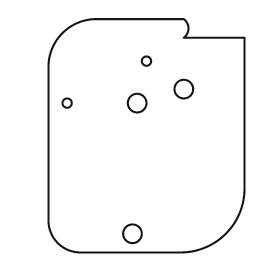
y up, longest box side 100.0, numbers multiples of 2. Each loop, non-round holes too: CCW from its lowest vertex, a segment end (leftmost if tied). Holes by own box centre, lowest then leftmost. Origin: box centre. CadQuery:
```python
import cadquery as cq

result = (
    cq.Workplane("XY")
    .moveTo(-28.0, -50.0)
    .lineTo(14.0, -50.0)
    .threePointArc((34.0, -42.0), (42.0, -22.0))
    .lineTo(42.0, 42.0)
    .lineTo(16.0, 42.0)
    .threePointArc((18.0, 46.0), (16.0, 50.0))
    .lineTo(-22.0, 50.0)
    .threePointArc((-36.0, 44.0), (-42.0, 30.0))
    .lineTo(-42.0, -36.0)
    .threePointArc((-38.0, -46.0), (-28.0, -50.0))
    .close()
    .moveTo(-6.0, -42.0)
    .circle(4.0)
    .moveTo(-34.0, 14.0)
    .circle(2.0)
    .moveTo(-4.0, 14.0)
    .circle(4.0)
    .moveTo(16.0, 20.0)
    .circle(4.0)
    .moveTo(0.0, 32.0)
    .circle(2.0)
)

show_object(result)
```